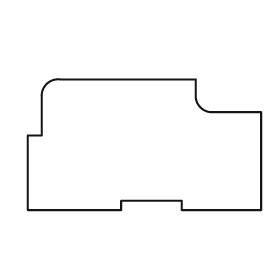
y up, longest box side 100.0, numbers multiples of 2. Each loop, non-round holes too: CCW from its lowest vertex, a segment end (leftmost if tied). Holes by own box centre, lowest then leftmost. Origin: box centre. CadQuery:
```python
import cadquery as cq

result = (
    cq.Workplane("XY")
    .moveTo(-50.0, -28.0)
    .lineTo(-10.0, -28.0)
    .lineTo(-10.0, -24.0)
    .lineTo(16.0, -24.0)
    .lineTo(16.0, -28.0)
    .lineTo(50.0, -28.0)
    .lineTo(50.0, 14.0)
    .lineTo(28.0, 14.0)
    .threePointArc((24.0, 16.0), (22.0, 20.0))
    .lineTo(22.0, 28.0)
    .lineTo(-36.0, 28.0)
    .threePointArc((-42.0, 26.0), (-44.0, 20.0))
    .lineTo(-44.0, 4.0)
    .lineTo(-50.0, 4.0)
    .close()
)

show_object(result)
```